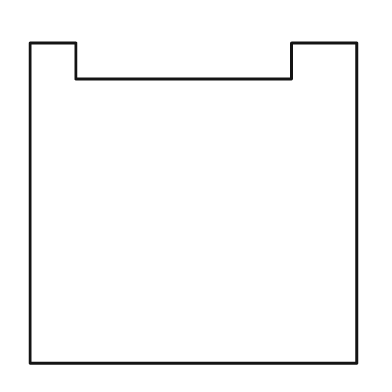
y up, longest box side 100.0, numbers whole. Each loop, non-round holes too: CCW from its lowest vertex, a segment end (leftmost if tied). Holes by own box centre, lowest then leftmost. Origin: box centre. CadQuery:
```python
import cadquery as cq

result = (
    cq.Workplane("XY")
    .moveTo(-50.0, -49.0)
    .lineTo(50.0, -49.0)
    .lineTo(50.0, 49.0)
    .lineTo(30.0, 49.0)
    .lineTo(30.0, 38.0)
    .lineTo(-36.0, 38.0)
    .lineTo(-36.0, 49.0)
    .lineTo(-50.0, 49.0)
    .close()
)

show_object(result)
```